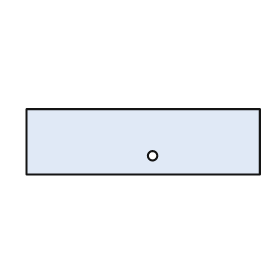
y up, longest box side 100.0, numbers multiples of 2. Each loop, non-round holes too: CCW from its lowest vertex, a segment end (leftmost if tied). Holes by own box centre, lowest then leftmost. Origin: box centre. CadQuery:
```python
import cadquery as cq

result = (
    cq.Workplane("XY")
    .moveTo(-50.0, -14.0)
    .lineTo(50.0, -14.0)
    .lineTo(50.0, 14.0)
    .lineTo(-50.0, 14.0)
    .close()
    .moveTo(4.0, -6.0)
    .circle(2.0)
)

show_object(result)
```